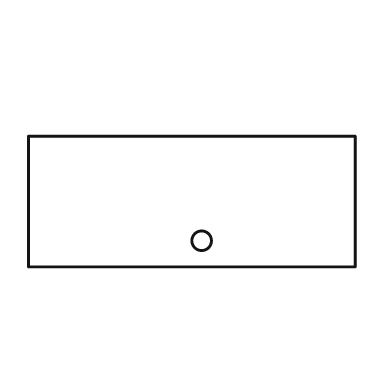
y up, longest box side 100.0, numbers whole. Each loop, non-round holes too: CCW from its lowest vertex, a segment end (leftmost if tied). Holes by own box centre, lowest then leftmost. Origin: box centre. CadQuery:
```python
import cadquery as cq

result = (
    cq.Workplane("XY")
    .moveTo(-50.0, -20.0)
    .lineTo(50.0, -20.0)
    .lineTo(50.0, 20.0)
    .lineTo(-50.0, 20.0)
    .close()
    .moveTo(3.0, -12.0)
    .circle(3.0)
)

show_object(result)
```